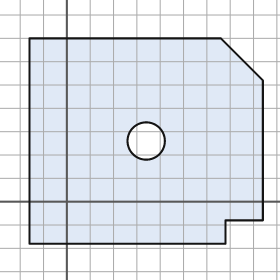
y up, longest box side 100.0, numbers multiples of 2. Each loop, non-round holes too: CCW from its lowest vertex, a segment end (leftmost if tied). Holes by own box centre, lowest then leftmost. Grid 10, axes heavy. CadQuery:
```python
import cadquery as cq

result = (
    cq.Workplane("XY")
    .moveTo(-16.0, -18.0)
    .lineTo(68.0, -18.0)
    .lineTo(68.0, -8.0)
    .lineTo(84.0, -8.0)
    .lineTo(84.0, 52.0)
    .lineTo(66.0, 70.0)
    .lineTo(-16.0, 70.0)
    .close()
    .moveTo(34.0, 26.0)
    .circle(8.0)
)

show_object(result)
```